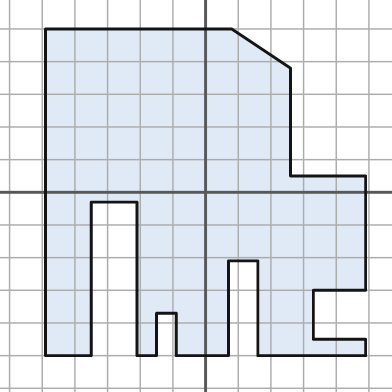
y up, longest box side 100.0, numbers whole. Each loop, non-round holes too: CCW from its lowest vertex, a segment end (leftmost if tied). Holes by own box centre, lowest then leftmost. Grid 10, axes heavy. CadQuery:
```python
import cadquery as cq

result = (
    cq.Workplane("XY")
    .moveTo(-49.0, -50.0)
    .lineTo(-35.0, -50.0)
    .lineTo(-35.0, -3.0)
    .lineTo(-21.0, -3.0)
    .lineTo(-21.0, -50.0)
    .lineTo(-15.0, -50.0)
    .lineTo(-15.0, -37.0)
    .lineTo(-9.0, -37.0)
    .lineTo(-9.0, -50.0)
    .lineTo(7.0, -50.0)
    .lineTo(7.0, -21.0)
    .lineTo(16.0, -21.0)
    .lineTo(16.0, -50.0)
    .lineTo(49.0, -50.0)
    .lineTo(49.0, -45.0)
    .lineTo(33.0, -45.0)
    .lineTo(33.0, -30.0)
    .lineTo(49.0, -30.0)
    .lineTo(49.0, 5.0)
    .lineTo(26.0, 5.0)
    .lineTo(26.0, 38.0)
    .lineTo(8.0, 50.0)
    .lineTo(-49.0, 50.0)
    .close()
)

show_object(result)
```